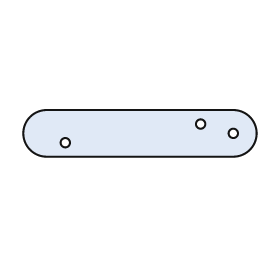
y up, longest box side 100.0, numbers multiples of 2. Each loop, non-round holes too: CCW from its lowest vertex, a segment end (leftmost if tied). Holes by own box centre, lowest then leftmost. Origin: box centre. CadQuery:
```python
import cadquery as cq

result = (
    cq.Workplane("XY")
    .moveTo(-40.0, -10.0)
    .lineTo(40.0, -10.0)
    .threePointArc((50.0, 0.0), (40.0, 10.0))
    .lineTo(-40.0, 10.0)
    .threePointArc((-50.0, 0.0), (-40.0, -10.0))
    .close()
    .moveTo(-32.0, -4.0)
    .circle(2.0)
    .moveTo(40.0, 0.0)
    .circle(2.0)
    .moveTo(26.0, 4.0)
    .circle(2.0)
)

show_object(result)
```